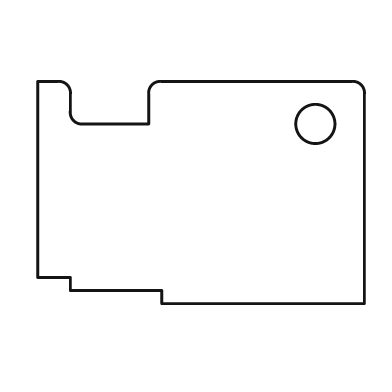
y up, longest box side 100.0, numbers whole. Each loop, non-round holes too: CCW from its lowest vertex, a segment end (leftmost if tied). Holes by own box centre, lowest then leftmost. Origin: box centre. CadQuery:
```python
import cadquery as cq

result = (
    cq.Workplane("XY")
    .moveTo(-12.0, -34.0)
    .lineTo(50.0, -34.0)
    .lineTo(50.0, 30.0)
    .threePointArc((49.0, 33.0), (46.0, 34.0))
    .lineTo(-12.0, 34.0)
    .threePointArc((-15.0, 33.0), (-16.0, 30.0))
    .lineTo(-16.0, 21.0)
    .lineTo(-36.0, 21.0)
    .threePointArc((-39.0, 22.0), (-40.0, 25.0))
    .lineTo(-40.0, 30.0)
    .threePointArc((-41.0, 33.0), (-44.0, 34.0))
    .lineTo(-50.0, 34.0)
    .lineTo(-50.0, -26.0)
    .lineTo(-40.0, -26.0)
    .lineTo(-40.0, -30.0)
    .lineTo(-12.0, -30.0)
    .close()
    .moveTo(35.0, 21.0)
    .circle(6.0)
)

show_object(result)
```